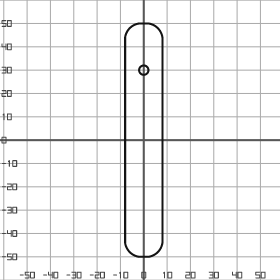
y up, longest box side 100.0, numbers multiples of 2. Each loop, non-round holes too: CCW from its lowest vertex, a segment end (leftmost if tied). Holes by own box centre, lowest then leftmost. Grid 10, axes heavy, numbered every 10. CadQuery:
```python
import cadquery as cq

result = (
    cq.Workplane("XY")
    .moveTo(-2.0, -50.0)
    .lineTo(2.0, -50.0)
    .threePointArc((6.0, -48.0), (8.0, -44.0))
    .lineTo(8.0, 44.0)
    .threePointArc((6.0, 48.0), (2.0, 50.0))
    .lineTo(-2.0, 50.0)
    .threePointArc((-6.0, 48.0), (-8.0, 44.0))
    .lineTo(-8.0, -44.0)
    .threePointArc((-6.0, -48.0), (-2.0, -50.0))
    .close()
    .moveTo(0.0, 30.0)
    .circle(2.0)
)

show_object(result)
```